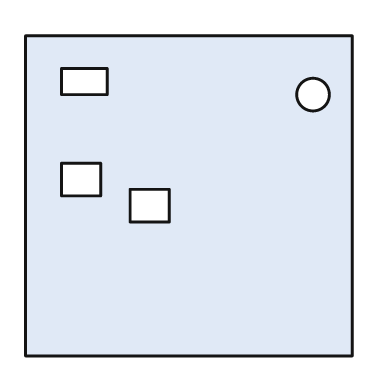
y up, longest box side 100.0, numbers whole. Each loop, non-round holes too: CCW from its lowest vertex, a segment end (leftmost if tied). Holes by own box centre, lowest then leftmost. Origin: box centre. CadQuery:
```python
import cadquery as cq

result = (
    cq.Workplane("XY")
    .moveTo(-50.0, -49.0)
    .lineTo(50.0, -49.0)
    .lineTo(50.0, 49.0)
    .lineTo(-50.0, 49.0)
    .close()
    .moveTo(-18.0, -8.0)
    .lineTo(-6.0, -8.0)
    .lineTo(-6.0, 2.0)
    .lineTo(-18.0, 2.0)
    .close()
    .moveTo(-39.0, 0.0)
    .lineTo(-27.0, 0.0)
    .lineTo(-27.0, 10.0)
    .lineTo(-39.0, 10.0)
    .close()
    .moveTo(38.0, 31.0)
    .circle(5.0)
    .moveTo(-39.0, 31.0)
    .lineTo(-25.0, 31.0)
    .lineTo(-25.0, 39.0)
    .lineTo(-39.0, 39.0)
    .close()
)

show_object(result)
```